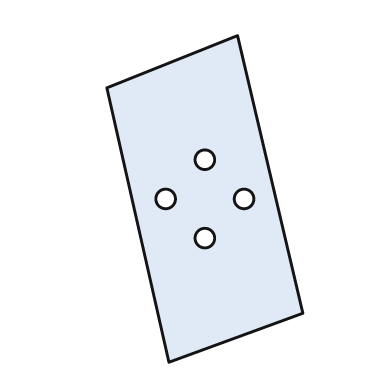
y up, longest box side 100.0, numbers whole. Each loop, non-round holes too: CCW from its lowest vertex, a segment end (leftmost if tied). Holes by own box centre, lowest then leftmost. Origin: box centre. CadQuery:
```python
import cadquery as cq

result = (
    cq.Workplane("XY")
    .moveTo(-11.0, -50.0)
    .lineTo(30.0, -35.0)
    .lineTo(10.0, 50.0)
    .lineTo(-30.0, 34.0)
    .close()
    .moveTo(0.0, -12.0)
    .circle(3.0)
    .moveTo(-12.0, 0.0)
    .circle(3.0)
    .moveTo(12.0, 0.0)
    .circle(3.0)
    .moveTo(0.0, 12.0)
    .circle(3.0)
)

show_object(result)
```